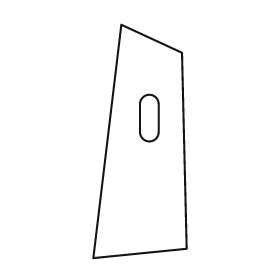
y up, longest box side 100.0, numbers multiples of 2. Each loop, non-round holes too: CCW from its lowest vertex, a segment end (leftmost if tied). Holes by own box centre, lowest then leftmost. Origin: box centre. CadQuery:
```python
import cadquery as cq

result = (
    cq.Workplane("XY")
    .moveTo(-20.0, -50.0)
    .lineTo(20.0, -46.0)
    .lineTo(18.0, 38.0)
    .lineTo(-8.0, 50.0)
    .close()
    .moveTo(0.0, 4.0)
    .threePointArc((4.0, 0.0), (8.0, 4.0))
    .lineTo(8.0, 16.0)
    .threePointArc((4.0, 20.0), (0.0, 16.0))
    .close()
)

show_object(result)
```